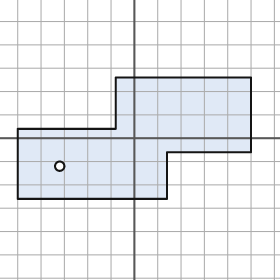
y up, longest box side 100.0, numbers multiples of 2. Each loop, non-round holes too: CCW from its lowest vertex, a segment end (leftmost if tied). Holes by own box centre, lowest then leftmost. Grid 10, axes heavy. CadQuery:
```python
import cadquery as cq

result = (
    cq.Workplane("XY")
    .moveTo(-50.0, -26.0)
    .lineTo(14.0, -26.0)
    .lineTo(14.0, -6.0)
    .lineTo(50.0, -6.0)
    .lineTo(50.0, 26.0)
    .lineTo(-8.0, 26.0)
    .lineTo(-8.0, 4.0)
    .lineTo(-50.0, 4.0)
    .close()
    .moveTo(-32.0, -12.0)
    .circle(2.0)
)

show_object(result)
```